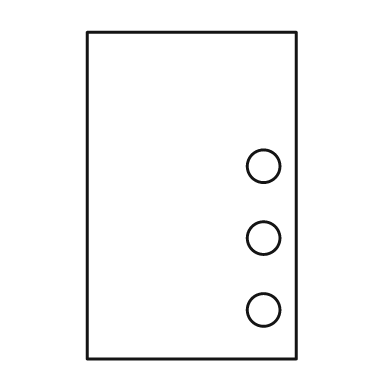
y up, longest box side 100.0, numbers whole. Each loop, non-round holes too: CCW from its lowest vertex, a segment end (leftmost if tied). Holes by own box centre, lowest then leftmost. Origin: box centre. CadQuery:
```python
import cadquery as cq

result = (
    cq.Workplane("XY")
    .moveTo(-32.0, -50.0)
    .lineTo(32.0, -50.0)
    .lineTo(32.0, 50.0)
    .lineTo(-32.0, 50.0)
    .close()
    .moveTo(22.0, -35.0)
    .circle(5.0)
    .moveTo(22.0, -13.0)
    .circle(5.0)
    .moveTo(22.0, 9.0)
    .circle(5.0)
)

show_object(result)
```